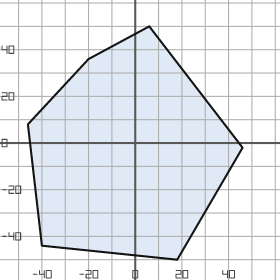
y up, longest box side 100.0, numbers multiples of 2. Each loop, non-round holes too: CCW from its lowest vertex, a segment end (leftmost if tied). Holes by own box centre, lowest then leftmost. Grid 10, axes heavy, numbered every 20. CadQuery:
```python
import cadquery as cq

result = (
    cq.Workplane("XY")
    .moveTo(18.0, -50.0)
    .lineTo(46.0, -2.0)
    .lineTo(6.0, 50.0)
    .lineTo(-20.0, 36.0)
    .lineTo(-46.0, 8.0)
    .lineTo(-40.0, -44.0)
    .close()
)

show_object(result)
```